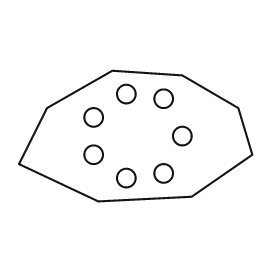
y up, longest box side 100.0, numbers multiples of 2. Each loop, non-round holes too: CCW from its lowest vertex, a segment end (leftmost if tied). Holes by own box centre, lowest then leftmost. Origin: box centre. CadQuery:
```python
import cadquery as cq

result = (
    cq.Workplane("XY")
    .moveTo(-16.0, -28.0)
    .lineTo(24.0, -26.0)
    .lineTo(50.0, -8.0)
    .lineTo(44.0, 12.0)
    .lineTo(20.0, 26.0)
    .lineTo(-10.0, 28.0)
    .lineTo(-38.0, 12.0)
    .lineTo(-50.0, -12.0)
    .close()
    .moveTo(-4.0, -18.0)
    .circle(4.0)
    .moveTo(12.0, -16.0)
    .circle(4.0)
    .moveTo(-18.0, -8.0)
    .circle(4.0)
    .moveTo(20.0, 0.0)
    .circle(4.0)
    .moveTo(-18.0, 8.0)
    .circle(4.0)
    .moveTo(12.0, 16.0)
    .circle(4.0)
    .moveTo(-4.0, 18.0)
    .circle(4.0)
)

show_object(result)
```